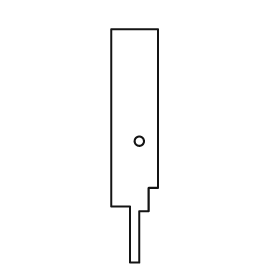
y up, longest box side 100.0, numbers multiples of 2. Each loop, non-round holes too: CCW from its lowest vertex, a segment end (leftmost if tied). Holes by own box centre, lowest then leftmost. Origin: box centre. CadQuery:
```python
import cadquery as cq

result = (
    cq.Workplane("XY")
    .moveTo(-2.0, -50.0)
    .lineTo(2.0, -50.0)
    .lineTo(2.0, -28.0)
    .lineTo(6.0, -28.0)
    .lineTo(6.0, -18.0)
    .lineTo(10.0, -18.0)
    .lineTo(10.0, 50.0)
    .lineTo(-10.0, 50.0)
    .lineTo(-10.0, -26.0)
    .lineTo(-2.0, -26.0)
    .close()
    .moveTo(2.0, 2.0)
    .circle(2.0)
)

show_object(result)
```